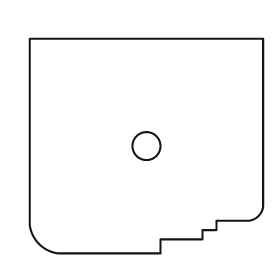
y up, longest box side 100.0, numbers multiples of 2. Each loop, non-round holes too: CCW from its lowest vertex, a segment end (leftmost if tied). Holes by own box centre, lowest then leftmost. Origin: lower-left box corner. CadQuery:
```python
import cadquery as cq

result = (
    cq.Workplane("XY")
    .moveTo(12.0, 0.0)
    .lineTo(56.0, 0.0)
    .lineTo(56.0, 6.0)
    .lineTo(74.0, 6.0)
    .lineTo(74.0, 10.0)
    .lineTo(80.0, 10.0)
    .lineTo(80.0, 14.0)
    .lineTo(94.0, 14.0)
    .threePointArc((98.0, 16.0), (100.0, 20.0))
    .lineTo(100.0, 92.0)
    .lineTo(0.0, 92.0)
    .lineTo(0.0, 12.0)
    .threePointArc((4.0, 4.0), (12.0, 0.0))
    .close()
    .moveTo(50.0, 46.0)
    .circle(6.0)
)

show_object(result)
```